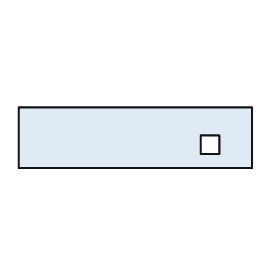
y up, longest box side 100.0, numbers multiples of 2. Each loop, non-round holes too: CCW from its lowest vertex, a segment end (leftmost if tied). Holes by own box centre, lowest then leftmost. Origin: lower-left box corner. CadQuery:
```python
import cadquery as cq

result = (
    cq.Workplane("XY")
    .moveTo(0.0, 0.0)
    .lineTo(100.0, 0.0)
    .lineTo(100.0, 26.0)
    .lineTo(0.0, 26.0)
    .close()
    .moveTo(78.0, 6.0)
    .lineTo(86.0, 6.0)
    .lineTo(86.0, 14.0)
    .lineTo(78.0, 14.0)
    .close()
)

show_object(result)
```